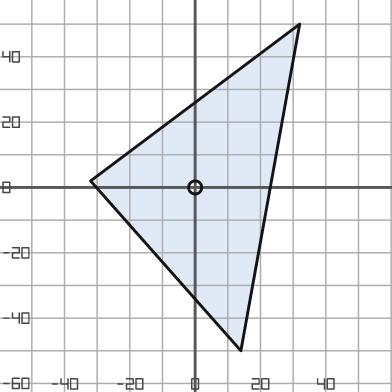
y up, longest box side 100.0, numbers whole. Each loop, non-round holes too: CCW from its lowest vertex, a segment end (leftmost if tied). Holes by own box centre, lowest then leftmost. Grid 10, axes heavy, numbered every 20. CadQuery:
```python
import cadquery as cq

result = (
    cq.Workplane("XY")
    .moveTo(14.0, -50.0)
    .lineTo(32.0, 50.0)
    .lineTo(-32.0, 2.0)
    .close()
    .moveTo(0.0, 0.0)
    .circle(2.0)
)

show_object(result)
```